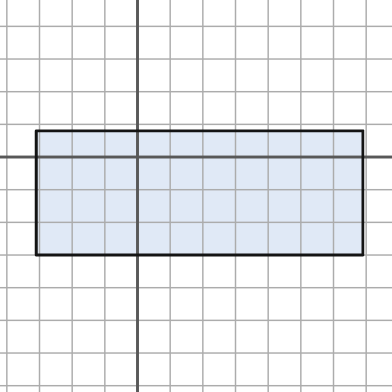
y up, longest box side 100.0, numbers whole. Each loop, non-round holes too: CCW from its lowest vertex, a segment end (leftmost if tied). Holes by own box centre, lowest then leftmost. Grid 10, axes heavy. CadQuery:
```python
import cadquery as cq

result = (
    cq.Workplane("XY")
    .moveTo(-31.0, -30.0)
    .lineTo(69.0, -30.0)
    .lineTo(69.0, 8.0)
    .lineTo(-31.0, 8.0)
    .close()
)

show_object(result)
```